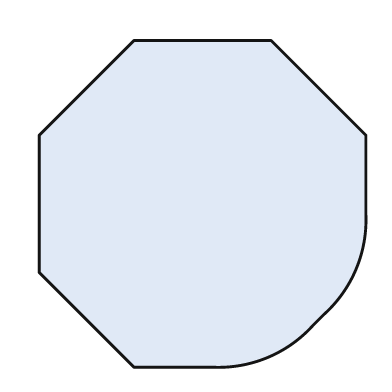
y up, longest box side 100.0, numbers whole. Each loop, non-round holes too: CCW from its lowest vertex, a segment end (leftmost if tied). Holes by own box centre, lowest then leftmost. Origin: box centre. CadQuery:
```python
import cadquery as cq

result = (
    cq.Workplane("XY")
    .moveTo(-21.0, -50.0)
    .lineTo(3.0, -50.0)
    .threePointArc((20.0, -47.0), (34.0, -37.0))
    .lineTo(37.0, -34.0)
    .threePointArc((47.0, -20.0), (50.0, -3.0))
    .lineTo(50.0, 21.0)
    .lineTo(21.0, 50.0)
    .lineTo(-21.0, 50.0)
    .lineTo(-50.0, 21.0)
    .lineTo(-50.0, -21.0)
    .close()
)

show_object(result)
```